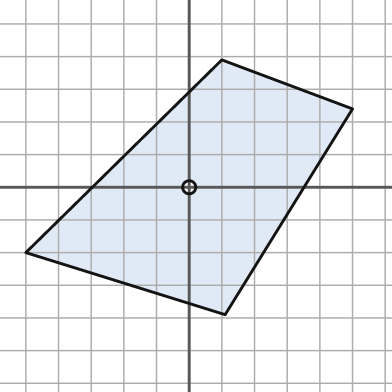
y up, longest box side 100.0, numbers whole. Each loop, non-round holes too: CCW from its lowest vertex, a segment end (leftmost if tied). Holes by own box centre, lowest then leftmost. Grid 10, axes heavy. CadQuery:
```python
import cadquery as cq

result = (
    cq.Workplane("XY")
    .moveTo(11.0, -39.0)
    .lineTo(50.0, 24.0)
    .lineTo(10.0, 39.0)
    .lineTo(-50.0, -20.0)
    .close()
    .moveTo(0.0, 0.0)
    .circle(2.0)
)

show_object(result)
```